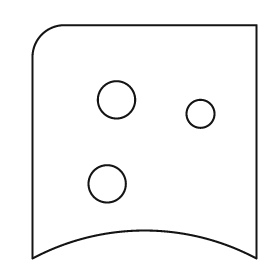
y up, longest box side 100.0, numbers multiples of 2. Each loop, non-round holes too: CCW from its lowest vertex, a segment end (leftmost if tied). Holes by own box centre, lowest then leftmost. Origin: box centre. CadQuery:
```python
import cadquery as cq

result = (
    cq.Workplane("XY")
    .moveTo(-48.0, -50.0)
    .threePointArc((0.0, -38.0), (48.0, -50.0))
    .lineTo(48.0, 50.0)
    .lineTo(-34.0, 50.0)
    .threePointArc((-44.0, 46.0), (-48.0, 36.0))
    .close()
    .moveTo(-16.0, -18.0)
    .circle(8.0)
    .moveTo(24.0, 12.0)
    .circle(6.0)
    .moveTo(-12.0, 18.0)
    .circle(8.0)
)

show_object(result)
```